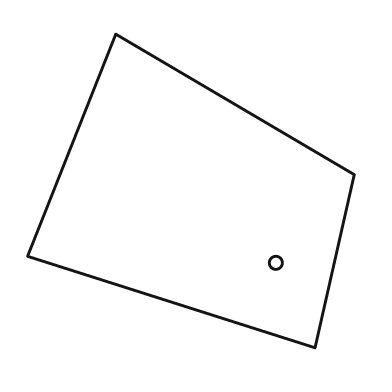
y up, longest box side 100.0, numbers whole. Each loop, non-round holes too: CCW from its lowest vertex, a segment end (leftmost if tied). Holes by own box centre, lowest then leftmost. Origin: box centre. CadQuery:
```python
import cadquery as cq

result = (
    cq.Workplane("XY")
    .moveTo(38.0, -48.0)
    .lineTo(50.0, 5.0)
    .lineTo(-23.0, 48.0)
    .lineTo(-50.0, -20.0)
    .close()
    .moveTo(26.0, -22.0)
    .circle(2.0)
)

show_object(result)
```